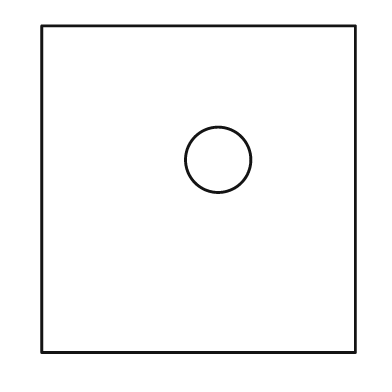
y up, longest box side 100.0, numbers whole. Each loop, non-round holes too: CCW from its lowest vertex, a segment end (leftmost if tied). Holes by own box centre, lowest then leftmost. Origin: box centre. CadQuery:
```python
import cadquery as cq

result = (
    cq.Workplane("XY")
    .moveTo(-48.0, -50.0)
    .lineTo(48.0, -50.0)
    .lineTo(48.0, 50.0)
    .lineTo(-48.0, 50.0)
    .close()
    .moveTo(6.0, 9.0)
    .circle(10.0)
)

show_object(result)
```